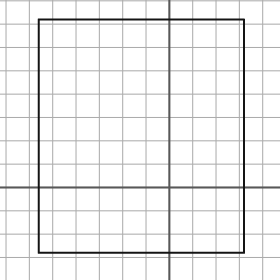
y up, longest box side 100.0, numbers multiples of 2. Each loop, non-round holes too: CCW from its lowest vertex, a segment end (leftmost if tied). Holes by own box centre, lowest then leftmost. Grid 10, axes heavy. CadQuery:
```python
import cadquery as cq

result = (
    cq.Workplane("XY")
    .moveTo(-56.0, -28.0)
    .lineTo(32.0, -28.0)
    .lineTo(32.0, 72.0)
    .lineTo(-56.0, 72.0)
    .close()
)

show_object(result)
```